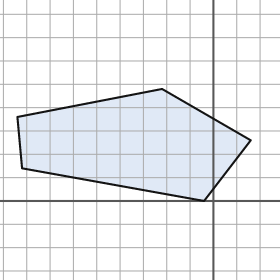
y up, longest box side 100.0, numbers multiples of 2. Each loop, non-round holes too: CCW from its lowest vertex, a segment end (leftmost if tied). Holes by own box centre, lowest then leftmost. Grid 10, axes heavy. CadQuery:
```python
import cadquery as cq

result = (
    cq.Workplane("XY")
    .moveTo(-4.0, 0.0)
    .lineTo(16.0, 26.0)
    .lineTo(-22.0, 48.0)
    .lineTo(-84.0, 36.0)
    .lineTo(-82.0, 14.0)
    .close()
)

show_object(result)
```